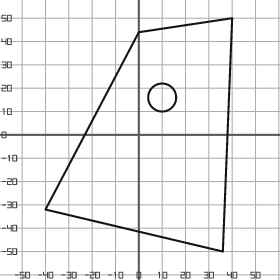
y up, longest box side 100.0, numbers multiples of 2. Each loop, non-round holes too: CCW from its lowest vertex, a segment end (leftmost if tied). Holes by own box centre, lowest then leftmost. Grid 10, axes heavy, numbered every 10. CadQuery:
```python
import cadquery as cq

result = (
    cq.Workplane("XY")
    .moveTo(36.0, -50.0)
    .lineTo(40.0, 50.0)
    .lineTo(0.0, 44.0)
    .lineTo(-40.0, -32.0)
    .close()
    .moveTo(10.0, 16.0)
    .circle(6.0)
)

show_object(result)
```